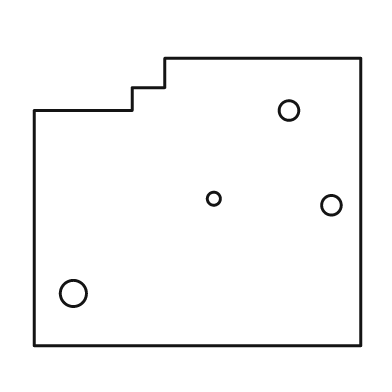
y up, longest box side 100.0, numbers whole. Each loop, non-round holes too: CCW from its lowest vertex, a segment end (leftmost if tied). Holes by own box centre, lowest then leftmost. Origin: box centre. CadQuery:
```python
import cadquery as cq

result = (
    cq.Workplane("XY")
    .moveTo(-50.0, -44.0)
    .lineTo(50.0, -44.0)
    .lineTo(50.0, 44.0)
    .lineTo(-10.0, 44.0)
    .lineTo(-10.0, 35.0)
    .lineTo(-20.0, 35.0)
    .lineTo(-20.0, 28.0)
    .lineTo(-50.0, 28.0)
    .close()
    .moveTo(-38.0, -28.0)
    .circle(4.0)
    .moveTo(41.0, -1.0)
    .circle(3.0)
    .moveTo(5.0, 1.0)
    .circle(2.0)
    .moveTo(28.0, 28.0)
    .circle(3.0)
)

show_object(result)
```